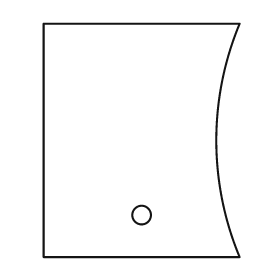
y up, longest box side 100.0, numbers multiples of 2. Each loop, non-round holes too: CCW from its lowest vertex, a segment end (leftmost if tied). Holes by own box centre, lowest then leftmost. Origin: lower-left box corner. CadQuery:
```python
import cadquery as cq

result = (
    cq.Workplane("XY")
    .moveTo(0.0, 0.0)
    .lineTo(84.0, 0.0)
    .threePointArc((74.0, 50.0), (84.0, 100.0))
    .lineTo(0.0, 100.0)
    .close()
    .moveTo(42.0, 18.0)
    .circle(4.0)
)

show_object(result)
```